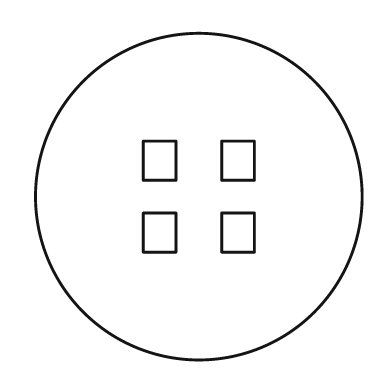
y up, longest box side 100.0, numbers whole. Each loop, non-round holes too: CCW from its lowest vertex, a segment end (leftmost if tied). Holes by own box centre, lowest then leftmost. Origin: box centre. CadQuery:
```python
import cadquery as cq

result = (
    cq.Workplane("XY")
    .moveTo(0.0, 0.0)
    .circle(50.0)
    .moveTo(-17.0, -17.0)
    .lineTo(-7.0, -17.0)
    .lineTo(-7.0, -5.0)
    .lineTo(-17.0, -5.0)
    .close()
    .moveTo(7.0, -17.0)
    .lineTo(17.0, -17.0)
    .lineTo(17.0, -5.0)
    .lineTo(7.0, -5.0)
    .close()
    .moveTo(-17.0, 5.0)
    .lineTo(-7.0, 5.0)
    .lineTo(-7.0, 17.0)
    .lineTo(-17.0, 17.0)
    .close()
    .moveTo(7.0, 5.0)
    .lineTo(17.0, 5.0)
    .lineTo(17.0, 17.0)
    .lineTo(7.0, 17.0)
    .close()
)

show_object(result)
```